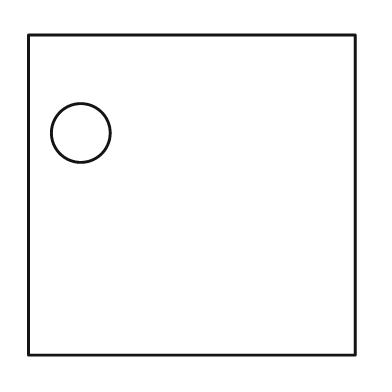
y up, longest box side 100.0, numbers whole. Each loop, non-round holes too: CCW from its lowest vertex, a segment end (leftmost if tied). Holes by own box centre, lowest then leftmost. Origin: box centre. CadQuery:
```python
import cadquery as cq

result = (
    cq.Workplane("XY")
    .moveTo(-50.0, -49.0)
    .lineTo(50.0, -49.0)
    .lineTo(50.0, 49.0)
    .lineTo(-50.0, 49.0)
    .close()
    .moveTo(-34.0, 19.0)
    .circle(9.0)
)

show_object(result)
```